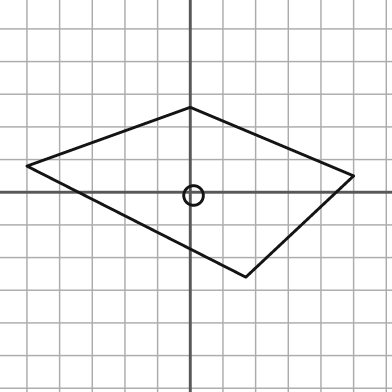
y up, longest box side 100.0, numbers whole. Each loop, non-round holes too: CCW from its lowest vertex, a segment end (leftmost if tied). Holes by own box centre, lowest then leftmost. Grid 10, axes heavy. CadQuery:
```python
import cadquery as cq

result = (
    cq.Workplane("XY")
    .moveTo(17.0, -26.0)
    .lineTo(50.0, 5.0)
    .lineTo(0.0, 26.0)
    .lineTo(-50.0, 8.0)
    .close()
    .moveTo(1.0, -1.0)
    .circle(3.0)
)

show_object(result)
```